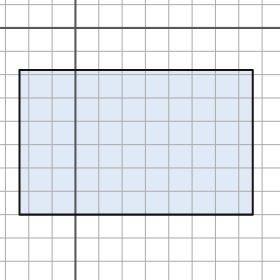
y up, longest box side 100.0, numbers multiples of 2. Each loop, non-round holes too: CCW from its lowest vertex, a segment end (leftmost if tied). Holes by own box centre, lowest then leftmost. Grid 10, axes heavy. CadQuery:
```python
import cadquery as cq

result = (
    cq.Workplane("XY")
    .moveTo(-24.0, -80.0)
    .lineTo(76.0, -80.0)
    .lineTo(76.0, -18.0)
    .lineTo(-24.0, -18.0)
    .close()
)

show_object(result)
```